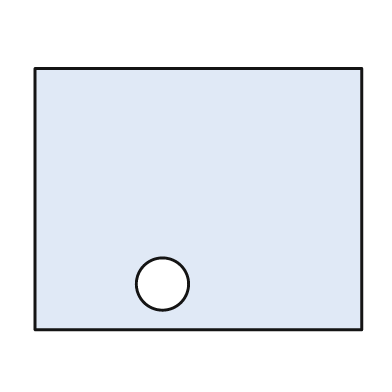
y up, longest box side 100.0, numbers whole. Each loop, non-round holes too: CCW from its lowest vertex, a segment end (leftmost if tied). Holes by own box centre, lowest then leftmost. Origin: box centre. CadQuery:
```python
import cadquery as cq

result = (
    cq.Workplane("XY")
    .moveTo(-50.0, -40.0)
    .lineTo(50.0, -40.0)
    .lineTo(50.0, 40.0)
    .lineTo(-50.0, 40.0)
    .close()
    .moveTo(-11.0, -26.0)
    .circle(8.0)
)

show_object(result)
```